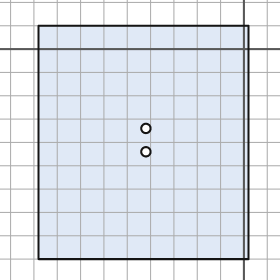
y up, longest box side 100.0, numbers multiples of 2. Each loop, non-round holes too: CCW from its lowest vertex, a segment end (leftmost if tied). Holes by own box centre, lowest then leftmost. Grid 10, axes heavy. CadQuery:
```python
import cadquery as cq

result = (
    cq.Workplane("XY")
    .moveTo(-88.0, -90.0)
    .lineTo(2.0, -90.0)
    .lineTo(2.0, 10.0)
    .lineTo(-88.0, 10.0)
    .close()
    .moveTo(-42.0, -44.0)
    .circle(2.0)
    .moveTo(-42.0, -34.0)
    .circle(2.0)
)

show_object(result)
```